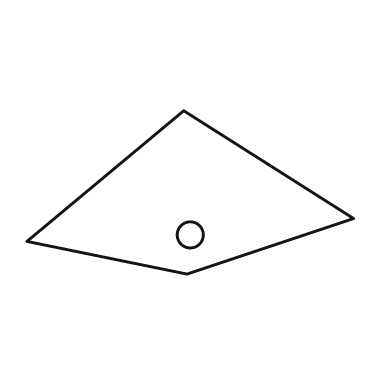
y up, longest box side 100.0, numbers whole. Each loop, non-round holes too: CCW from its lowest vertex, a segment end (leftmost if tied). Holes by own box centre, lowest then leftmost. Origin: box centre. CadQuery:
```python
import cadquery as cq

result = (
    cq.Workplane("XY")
    .moveTo(-1.0, -25.0)
    .lineTo(50.0, -8.0)
    .lineTo(-2.0, 25.0)
    .lineTo(-50.0, -15.0)
    .close()
    .moveTo(0.0, -13.0)
    .circle(4.0)
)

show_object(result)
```